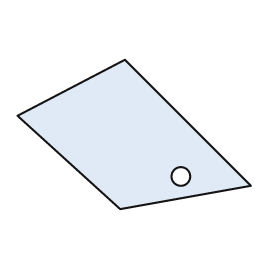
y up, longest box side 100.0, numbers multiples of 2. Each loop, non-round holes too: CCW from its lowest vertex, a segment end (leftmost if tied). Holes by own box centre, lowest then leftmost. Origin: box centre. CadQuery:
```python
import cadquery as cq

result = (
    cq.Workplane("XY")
    .moveTo(-6.0, -32.0)
    .lineTo(50.0, -22.0)
    .lineTo(-4.0, 32.0)
    .lineTo(-50.0, 8.0)
    .close()
    .moveTo(20.0, -18.0)
    .circle(4.0)
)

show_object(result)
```